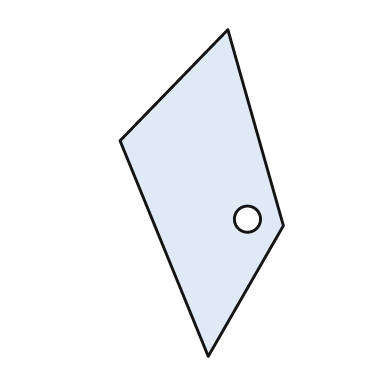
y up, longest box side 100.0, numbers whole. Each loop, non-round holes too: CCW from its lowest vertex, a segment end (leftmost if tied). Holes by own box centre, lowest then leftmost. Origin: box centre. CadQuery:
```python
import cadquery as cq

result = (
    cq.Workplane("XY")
    .moveTo(2.0, -50.0)
    .lineTo(25.0, -10.0)
    .lineTo(8.0, 50.0)
    .lineTo(-25.0, 16.0)
    .close()
    .moveTo(14.0, -8.0)
    .circle(4.0)
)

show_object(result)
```